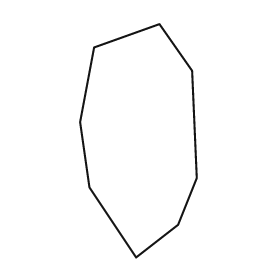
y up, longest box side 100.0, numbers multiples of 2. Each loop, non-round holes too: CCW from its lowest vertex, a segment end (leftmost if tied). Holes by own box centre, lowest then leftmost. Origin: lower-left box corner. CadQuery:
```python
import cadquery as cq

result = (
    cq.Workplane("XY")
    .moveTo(24.0, 0.0)
    .lineTo(42.0, 14.0)
    .lineTo(50.0, 34.0)
    .lineTo(48.0, 80.0)
    .lineTo(34.0, 100.0)
    .lineTo(6.0, 90.0)
    .lineTo(0.0, 58.0)
    .lineTo(4.0, 30.0)
    .close()
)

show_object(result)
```